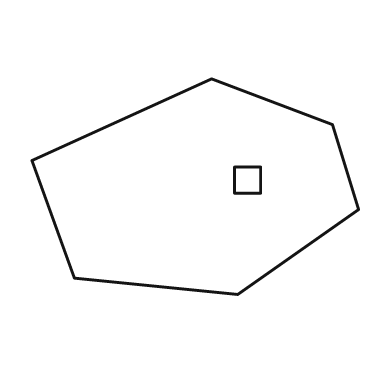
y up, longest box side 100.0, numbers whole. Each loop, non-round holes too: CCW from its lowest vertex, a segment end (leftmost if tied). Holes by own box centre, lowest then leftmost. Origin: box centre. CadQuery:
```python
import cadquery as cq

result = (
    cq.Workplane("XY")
    .moveTo(13.0, -33.0)
    .lineTo(50.0, -7.0)
    .lineTo(42.0, 19.0)
    .lineTo(5.0, 33.0)
    .lineTo(-50.0, 8.0)
    .lineTo(-37.0, -28.0)
    .close()
    .moveTo(12.0, -2.0)
    .lineTo(20.0, -2.0)
    .lineTo(20.0, 6.0)
    .lineTo(12.0, 6.0)
    .close()
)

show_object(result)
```